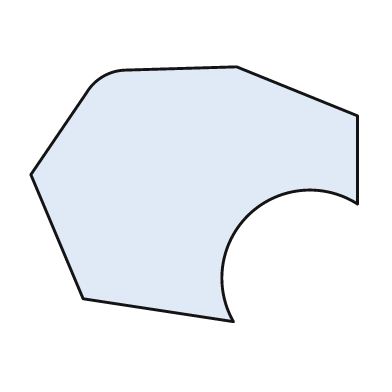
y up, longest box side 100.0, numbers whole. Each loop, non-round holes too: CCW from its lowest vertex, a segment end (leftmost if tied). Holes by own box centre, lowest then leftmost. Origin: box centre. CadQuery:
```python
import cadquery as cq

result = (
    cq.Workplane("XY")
    .moveTo(12.0, -39.0)
    .threePointArc((17.0, -6.0), (50.0, -3.0))
    .lineTo(50.0, 24.0)
    .lineTo(13.0, 39.0)
    .lineTo(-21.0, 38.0)
    .threePointArc((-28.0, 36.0), (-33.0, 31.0))
    .lineTo(-50.0, 6.0)
    .lineTo(-34.0, -32.0)
    .close()
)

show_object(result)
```